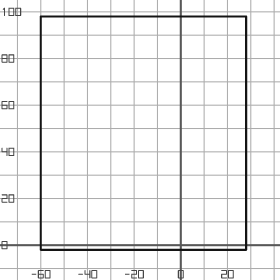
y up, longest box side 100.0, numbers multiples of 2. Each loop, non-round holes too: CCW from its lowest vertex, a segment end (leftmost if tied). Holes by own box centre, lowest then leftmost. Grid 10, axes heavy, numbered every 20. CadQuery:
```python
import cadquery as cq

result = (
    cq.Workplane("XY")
    .moveTo(-60.0, -2.0)
    .lineTo(28.0, -2.0)
    .lineTo(28.0, 98.0)
    .lineTo(-60.0, 98.0)
    .close()
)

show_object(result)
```